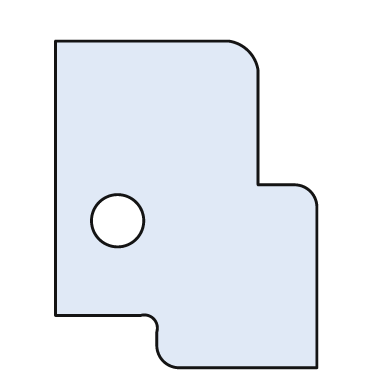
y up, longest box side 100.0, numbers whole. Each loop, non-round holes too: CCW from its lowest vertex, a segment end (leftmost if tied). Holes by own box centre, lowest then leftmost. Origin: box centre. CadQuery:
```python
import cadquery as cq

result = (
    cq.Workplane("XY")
    .moveTo(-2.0, -50.0)
    .lineTo(40.0, -50.0)
    .lineTo(40.0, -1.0)
    .threePointArc((38.0, 4.0), (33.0, 6.0))
    .lineTo(22.0, 6.0)
    .lineTo(22.0, 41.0)
    .threePointArc((19.0, 47.0), (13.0, 50.0))
    .lineTo(-40.0, 50.0)
    .lineTo(-40.0, -34.0)
    .lineTo(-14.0, -34.0)
    .threePointArc((-10.0, -35.0), (-9.0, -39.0))
    .lineTo(-9.0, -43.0)
    .threePointArc((-7.0, -48.0), (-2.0, -50.0))
    .close()
    .moveTo(-21.0, -5.0)
    .circle(8.0)
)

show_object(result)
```